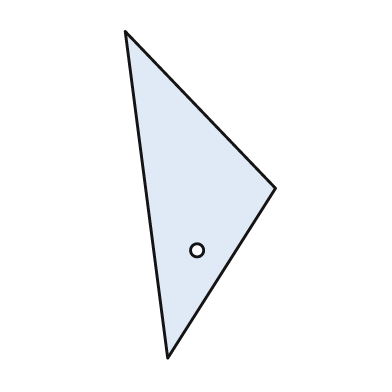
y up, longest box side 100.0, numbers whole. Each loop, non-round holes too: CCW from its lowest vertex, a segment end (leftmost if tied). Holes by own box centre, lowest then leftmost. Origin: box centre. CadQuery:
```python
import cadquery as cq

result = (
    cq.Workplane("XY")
    .moveTo(-10.0, -50.0)
    .lineTo(23.0, 2.0)
    .lineTo(-23.0, 50.0)
    .close()
    .moveTo(-1.0, -17.0)
    .circle(2.0)
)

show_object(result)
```